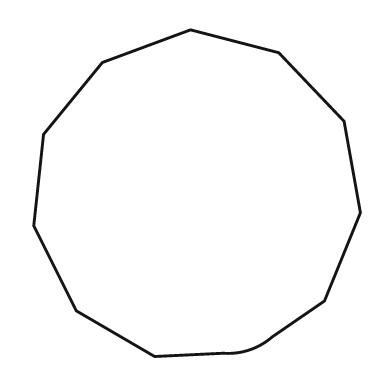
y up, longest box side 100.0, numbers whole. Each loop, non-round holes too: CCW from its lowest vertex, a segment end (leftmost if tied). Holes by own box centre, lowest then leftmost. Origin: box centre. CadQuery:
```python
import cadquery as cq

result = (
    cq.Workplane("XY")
    .moveTo(-13.0, -50.0)
    .lineTo(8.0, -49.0)
    .threePointArc((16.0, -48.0), (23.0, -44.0))
    .lineTo(39.0, -33.0)
    .lineTo(50.0, -6.0)
    .lineTo(45.0, 22.0)
    .lineTo(25.0, 43.0)
    .lineTo(-2.0, 50.0)
    .lineTo(-29.0, 40.0)
    .lineTo(-47.0, 18.0)
    .lineTo(-50.0, -10.0)
    .lineTo(-37.0, -36.0)
    .close()
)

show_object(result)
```